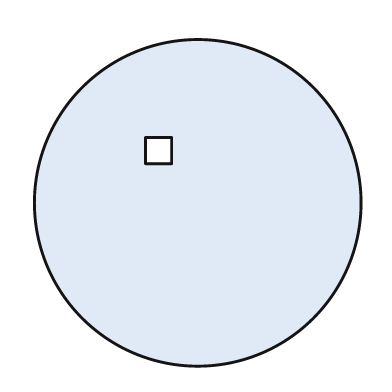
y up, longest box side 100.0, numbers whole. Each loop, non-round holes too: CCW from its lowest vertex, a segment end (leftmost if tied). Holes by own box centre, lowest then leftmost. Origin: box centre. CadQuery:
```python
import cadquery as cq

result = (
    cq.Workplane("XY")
    .moveTo(0.0, 0.0)
    .circle(50.0)
    .moveTo(-16.0, 12.0)
    .lineTo(-8.0, 12.0)
    .lineTo(-8.0, 20.0)
    .lineTo(-16.0, 20.0)
    .close()
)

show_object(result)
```